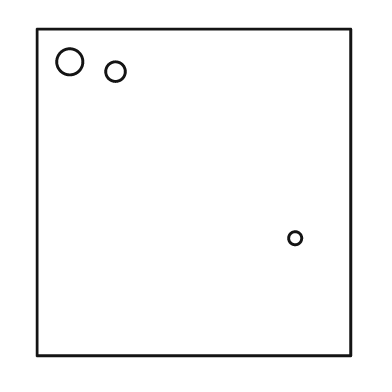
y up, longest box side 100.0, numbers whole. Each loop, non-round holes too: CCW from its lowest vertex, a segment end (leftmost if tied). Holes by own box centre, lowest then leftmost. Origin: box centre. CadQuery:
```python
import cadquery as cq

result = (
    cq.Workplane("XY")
    .moveTo(-48.0, -50.0)
    .lineTo(48.0, -50.0)
    .lineTo(48.0, 50.0)
    .lineTo(-48.0, 50.0)
    .close()
    .moveTo(31.0, -14.0)
    .circle(2.0)
    .moveTo(-24.0, 37.0)
    .circle(3.0)
    .moveTo(-38.0, 40.0)
    .circle(4.0)
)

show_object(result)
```